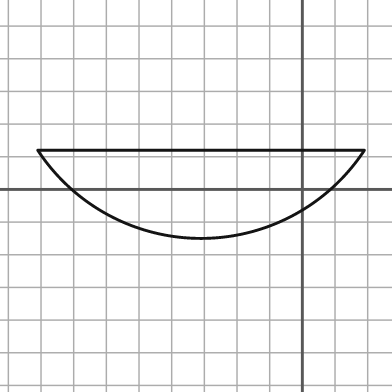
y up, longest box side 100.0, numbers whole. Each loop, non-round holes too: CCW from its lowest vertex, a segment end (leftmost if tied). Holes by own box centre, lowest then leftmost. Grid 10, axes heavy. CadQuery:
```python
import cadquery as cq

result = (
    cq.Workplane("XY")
    .moveTo(-81.0, 12.0)
    .threePointArc((-31.0, -15.0), (19.0, 12.0))
    .close()
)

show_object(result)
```